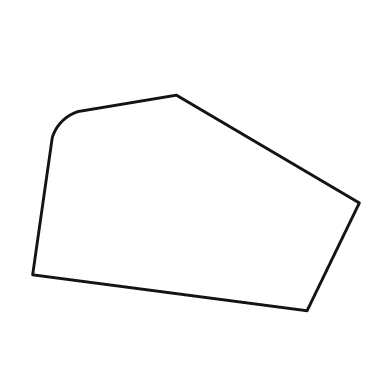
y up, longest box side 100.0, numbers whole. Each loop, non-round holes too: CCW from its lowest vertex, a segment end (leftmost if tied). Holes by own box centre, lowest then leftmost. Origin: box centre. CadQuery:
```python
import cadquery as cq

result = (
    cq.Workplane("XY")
    .moveTo(34.0, -33.0)
    .lineTo(50.0, 0.0)
    .lineTo(-6.0, 33.0)
    .lineTo(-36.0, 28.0)
    .threePointArc((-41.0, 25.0), (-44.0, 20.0))
    .lineTo(-50.0, -22.0)
    .close()
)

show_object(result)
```